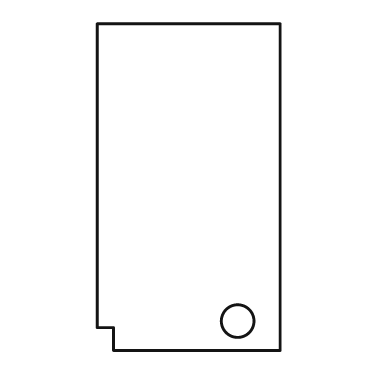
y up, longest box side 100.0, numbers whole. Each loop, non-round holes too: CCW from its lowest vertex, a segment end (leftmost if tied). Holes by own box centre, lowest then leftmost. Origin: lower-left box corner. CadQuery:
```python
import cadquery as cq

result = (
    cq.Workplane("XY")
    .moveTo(5.0, 0.0)
    .lineTo(56.0, 0.0)
    .lineTo(56.0, 100.0)
    .lineTo(0.0, 100.0)
    .lineTo(0.0, 7.0)
    .lineTo(5.0, 7.0)
    .close()
    .moveTo(43.0, 9.0)
    .circle(5.0)
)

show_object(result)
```